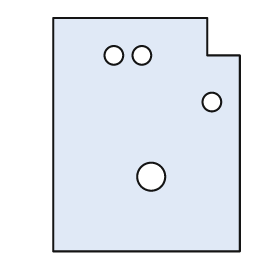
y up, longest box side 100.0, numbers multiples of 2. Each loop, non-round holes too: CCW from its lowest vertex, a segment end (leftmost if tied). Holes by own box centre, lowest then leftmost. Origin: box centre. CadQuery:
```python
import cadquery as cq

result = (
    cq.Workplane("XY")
    .moveTo(-40.0, -50.0)
    .lineTo(40.0, -50.0)
    .lineTo(40.0, 34.0)
    .lineTo(26.0, 34.0)
    .lineTo(26.0, 50.0)
    .lineTo(-40.0, 50.0)
    .close()
    .moveTo(2.0, -18.0)
    .circle(6.0)
    .moveTo(28.0, 14.0)
    .circle(4.0)
    .moveTo(-14.0, 34.0)
    .circle(4.0)
    .moveTo(-2.0, 34.0)
    .circle(4.0)
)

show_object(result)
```